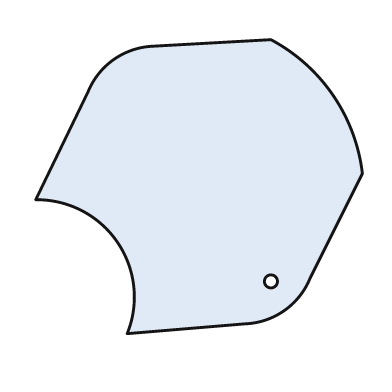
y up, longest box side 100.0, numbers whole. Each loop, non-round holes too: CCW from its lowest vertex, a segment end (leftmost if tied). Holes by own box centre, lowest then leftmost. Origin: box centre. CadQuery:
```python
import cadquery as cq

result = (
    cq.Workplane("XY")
    .moveTo(-22.0, -45.0)
    .lineTo(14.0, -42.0)
    .threePointArc((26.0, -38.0), (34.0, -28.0))
    .lineTo(50.0, 4.0)
    .threePointArc((41.0, 28.0), (22.0, 45.0))
    .lineTo(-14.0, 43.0)
    .threePointArc((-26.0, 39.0), (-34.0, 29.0))
    .lineTo(-50.0, -4.0)
    .threePointArc((-25.0, -17.0), (-22.0, -45.0))
    .close()
    .moveTo(22.0, -29.0)
    .circle(2.0)
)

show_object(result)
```